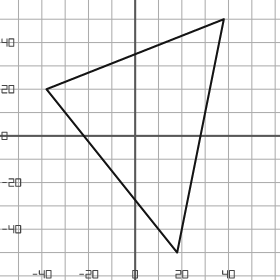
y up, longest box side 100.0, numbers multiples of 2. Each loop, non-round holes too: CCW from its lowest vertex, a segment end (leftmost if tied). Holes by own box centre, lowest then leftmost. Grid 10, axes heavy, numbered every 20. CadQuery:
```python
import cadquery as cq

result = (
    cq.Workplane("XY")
    .moveTo(18.0, -50.0)
    .lineTo(38.0, 50.0)
    .lineTo(-38.0, 20.0)
    .close()
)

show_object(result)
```